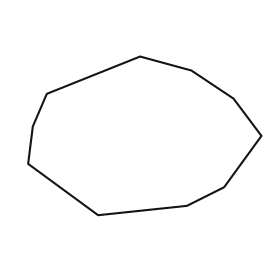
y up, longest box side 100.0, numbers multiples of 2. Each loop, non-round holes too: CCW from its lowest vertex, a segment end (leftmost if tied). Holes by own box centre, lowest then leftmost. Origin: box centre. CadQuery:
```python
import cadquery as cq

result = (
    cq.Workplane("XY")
    .moveTo(-20.0, -34.0)
    .lineTo(18.0, -30.0)
    .lineTo(34.0, -22.0)
    .lineTo(50.0, 0.0)
    .lineTo(38.0, 16.0)
    .lineTo(20.0, 28.0)
    .lineTo(-2.0, 34.0)
    .lineTo(-42.0, 18.0)
    .lineTo(-48.0, 4.0)
    .lineTo(-50.0, -12.0)
    .close()
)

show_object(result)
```